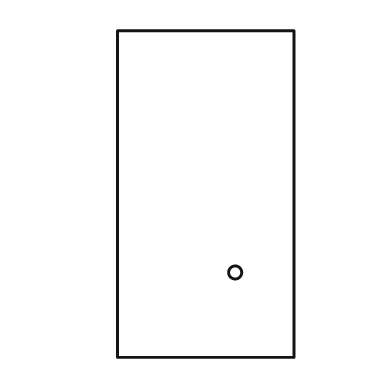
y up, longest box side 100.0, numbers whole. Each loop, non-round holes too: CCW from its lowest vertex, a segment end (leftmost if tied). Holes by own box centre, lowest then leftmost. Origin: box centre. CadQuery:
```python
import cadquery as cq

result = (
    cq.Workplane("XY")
    .moveTo(-27.0, -50.0)
    .lineTo(27.0, -50.0)
    .lineTo(27.0, 50.0)
    .lineTo(-27.0, 50.0)
    .close()
    .moveTo(9.0, -24.0)
    .circle(2.0)
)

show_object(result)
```